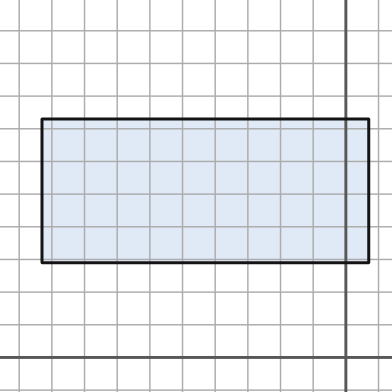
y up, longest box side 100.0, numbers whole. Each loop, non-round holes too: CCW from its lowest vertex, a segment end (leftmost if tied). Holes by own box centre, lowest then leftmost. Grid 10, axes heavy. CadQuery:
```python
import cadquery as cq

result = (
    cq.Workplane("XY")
    .moveTo(-93.0, 29.0)
    .lineTo(7.0, 29.0)
    .lineTo(7.0, 73.0)
    .lineTo(-93.0, 73.0)
    .close()
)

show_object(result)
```